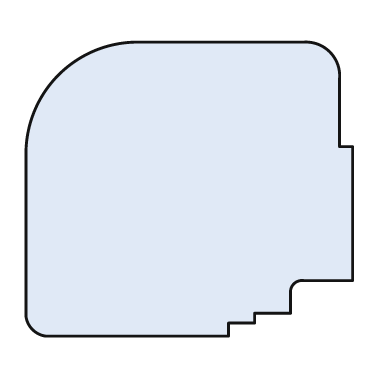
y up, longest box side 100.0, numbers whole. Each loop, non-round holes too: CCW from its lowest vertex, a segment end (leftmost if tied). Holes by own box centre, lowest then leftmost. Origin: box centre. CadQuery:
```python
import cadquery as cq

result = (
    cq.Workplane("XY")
    .moveTo(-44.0, -45.0)
    .lineTo(12.0, -45.0)
    .lineTo(12.0, -41.0)
    .lineTo(20.0, -41.0)
    .lineTo(20.0, -38.0)
    .lineTo(31.0, -38.0)
    .lineTo(31.0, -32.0)
    .threePointArc((32.0, -29.0), (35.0, -28.0))
    .lineTo(50.0, -28.0)
    .lineTo(50.0, 13.0)
    .lineTo(46.0, 13.0)
    .lineTo(46.0, 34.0)
    .threePointArc((43.0, 42.0), (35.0, 45.0))
    .lineTo(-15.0, 45.0)
    .threePointArc((-40.0, 35.0), (-50.0, 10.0))
    .lineTo(-50.0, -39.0)
    .threePointArc((-48.0, -43.0), (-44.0, -45.0))
    .close()
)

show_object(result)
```